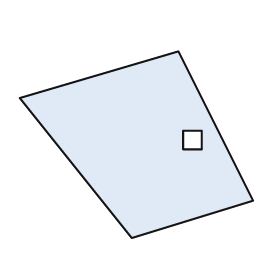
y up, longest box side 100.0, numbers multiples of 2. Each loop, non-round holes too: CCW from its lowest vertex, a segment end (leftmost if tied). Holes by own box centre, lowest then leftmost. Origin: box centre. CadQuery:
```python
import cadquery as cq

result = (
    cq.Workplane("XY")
    .moveTo(-2.0, -40.0)
    .lineTo(50.0, -24.0)
    .lineTo(18.0, 40.0)
    .lineTo(-50.0, 20.0)
    .close()
    .moveTo(20.0, -2.0)
    .lineTo(28.0, -2.0)
    .lineTo(28.0, 6.0)
    .lineTo(20.0, 6.0)
    .close()
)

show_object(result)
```